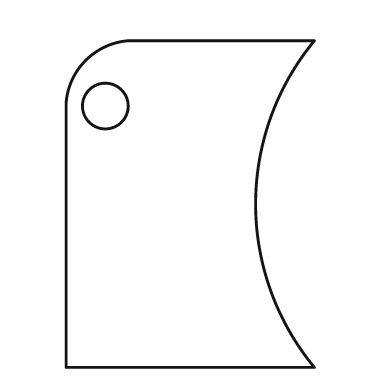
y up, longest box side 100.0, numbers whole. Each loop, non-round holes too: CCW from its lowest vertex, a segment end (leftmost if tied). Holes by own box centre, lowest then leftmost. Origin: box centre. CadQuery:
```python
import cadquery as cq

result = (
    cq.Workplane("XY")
    .moveTo(-38.0, -50.0)
    .lineTo(38.0, -50.0)
    .threePointArc((20.0, 0.0), (38.0, 50.0))
    .lineTo(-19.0, 50.0)
    .threePointArc((-32.0, 44.0), (-38.0, 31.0))
    .close()
    .moveTo(-26.0, 30.0)
    .circle(7.0)
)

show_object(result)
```